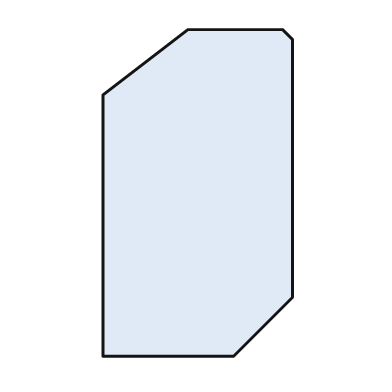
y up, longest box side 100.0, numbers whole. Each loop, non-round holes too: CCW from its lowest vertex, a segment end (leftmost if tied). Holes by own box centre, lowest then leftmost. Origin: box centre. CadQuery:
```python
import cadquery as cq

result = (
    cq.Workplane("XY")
    .moveTo(-29.0, -50.0)
    .lineTo(11.0, -50.0)
    .lineTo(29.0, -32.0)
    .lineTo(29.0, 47.0)
    .lineTo(26.0, 50.0)
    .lineTo(-3.0, 50.0)
    .lineTo(-29.0, 30.0)
    .close()
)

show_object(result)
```